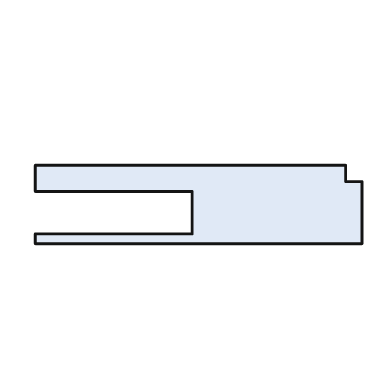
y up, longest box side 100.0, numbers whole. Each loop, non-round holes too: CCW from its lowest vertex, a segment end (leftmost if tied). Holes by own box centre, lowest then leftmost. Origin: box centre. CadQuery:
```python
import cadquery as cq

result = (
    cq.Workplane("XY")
    .moveTo(-50.0, -12.0)
    .lineTo(50.0, -12.0)
    .lineTo(50.0, 7.0)
    .lineTo(45.0, 7.0)
    .lineTo(45.0, 12.0)
    .lineTo(-50.0, 12.0)
    .lineTo(-50.0, 4.0)
    .lineTo(-2.0, 4.0)
    .lineTo(-2.0, -9.0)
    .lineTo(-50.0, -9.0)
    .close()
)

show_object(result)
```